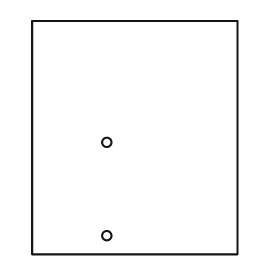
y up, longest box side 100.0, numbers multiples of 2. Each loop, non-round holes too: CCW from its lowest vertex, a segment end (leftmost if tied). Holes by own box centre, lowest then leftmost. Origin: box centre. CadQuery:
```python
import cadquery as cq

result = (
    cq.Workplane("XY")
    .moveTo(-44.0, -50.0)
    .lineTo(44.0, -50.0)
    .lineTo(44.0, 50.0)
    .lineTo(-44.0, 50.0)
    .close()
    .moveTo(-12.0, -42.0)
    .circle(2.0)
    .moveTo(-12.0, -2.0)
    .circle(2.0)
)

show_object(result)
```